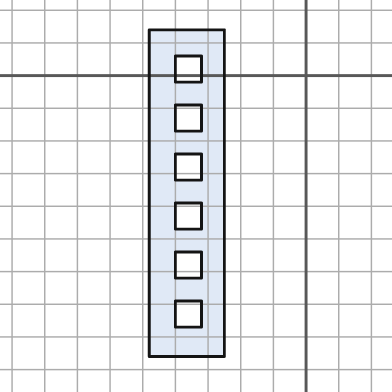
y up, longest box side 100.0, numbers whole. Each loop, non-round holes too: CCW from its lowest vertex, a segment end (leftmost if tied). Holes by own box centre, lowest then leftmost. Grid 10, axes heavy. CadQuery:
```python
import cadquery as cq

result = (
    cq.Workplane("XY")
    .moveTo(-48.0, -86.0)
    .lineTo(-25.0, -86.0)
    .lineTo(-25.0, 14.0)
    .lineTo(-48.0, 14.0)
    .close()
    .moveTo(-40.0, -77.0)
    .lineTo(-32.0, -77.0)
    .lineTo(-32.0, -69.0)
    .lineTo(-40.0, -69.0)
    .close()
    .moveTo(-40.0, -62.0)
    .lineTo(-32.0, -62.0)
    .lineTo(-32.0, -54.0)
    .lineTo(-40.0, -54.0)
    .close()
    .moveTo(-40.0, -47.0)
    .lineTo(-32.0, -47.0)
    .lineTo(-32.0, -39.0)
    .lineTo(-40.0, -39.0)
    .close()
    .moveTo(-40.0, -32.0)
    .lineTo(-32.0, -32.0)
    .lineTo(-32.0, -24.0)
    .lineTo(-40.0, -24.0)
    .close()
    .moveTo(-40.0, -17.0)
    .lineTo(-32.0, -17.0)
    .lineTo(-32.0, -9.0)
    .lineTo(-40.0, -9.0)
    .close()
    .moveTo(-40.0, -2.0)
    .lineTo(-32.0, -2.0)
    .lineTo(-32.0, 6.0)
    .lineTo(-40.0, 6.0)
    .close()
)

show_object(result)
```